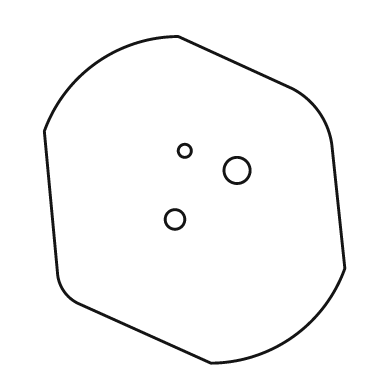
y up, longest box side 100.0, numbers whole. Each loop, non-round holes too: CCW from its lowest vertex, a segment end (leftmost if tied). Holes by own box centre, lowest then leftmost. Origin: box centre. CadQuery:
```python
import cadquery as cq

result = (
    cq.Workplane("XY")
    .moveTo(5.0, -50.0)
    .threePointArc((30.0, -42.0), (46.0, -21.0))
    .lineTo(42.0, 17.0)
    .threePointArc((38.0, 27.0), (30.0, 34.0))
    .lineTo(-5.0, 50.0)
    .threePointArc((-30.0, 42.0), (-46.0, 21.0))
    .lineTo(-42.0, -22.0)
    .threePointArc((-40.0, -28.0), (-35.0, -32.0))
    .close()
    .moveTo(-6.0, -6.0)
    .circle(3.0)
    .moveTo(13.0, 9.0)
    .circle(4.0)
    .moveTo(-3.0, 15.0)
    .circle(2.0)
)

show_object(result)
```